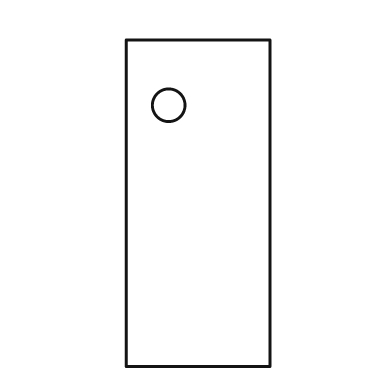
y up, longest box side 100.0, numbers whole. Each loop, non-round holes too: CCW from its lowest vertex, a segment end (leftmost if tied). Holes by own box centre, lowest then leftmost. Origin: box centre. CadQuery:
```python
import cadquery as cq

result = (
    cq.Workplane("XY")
    .moveTo(-22.0, -50.0)
    .lineTo(22.0, -50.0)
    .lineTo(22.0, 50.0)
    .lineTo(-22.0, 50.0)
    .close()
    .moveTo(-9.0, 30.0)
    .circle(5.0)
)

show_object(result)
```